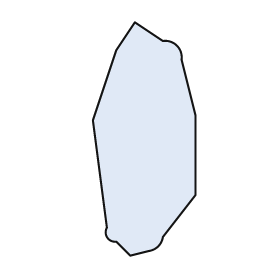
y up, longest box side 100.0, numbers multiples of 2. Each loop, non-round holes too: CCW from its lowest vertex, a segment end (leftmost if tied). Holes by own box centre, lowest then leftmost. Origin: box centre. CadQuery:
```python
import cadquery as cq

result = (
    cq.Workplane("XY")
    .moveTo(-6.0, -50.0)
    .lineTo(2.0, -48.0)
    .threePointArc((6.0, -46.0), (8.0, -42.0))
    .lineTo(22.0, -24.0)
    .lineTo(22.0, 10.0)
    .lineTo(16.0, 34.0)
    .threePointArc((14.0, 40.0), (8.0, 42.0))
    .lineTo(-4.0, 50.0)
    .lineTo(-12.0, 38.0)
    .lineTo(-22.0, 8.0)
    .lineTo(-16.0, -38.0)
    .threePointArc((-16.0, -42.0), (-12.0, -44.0))
    .close()
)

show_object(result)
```